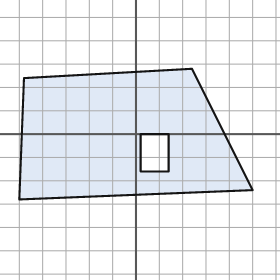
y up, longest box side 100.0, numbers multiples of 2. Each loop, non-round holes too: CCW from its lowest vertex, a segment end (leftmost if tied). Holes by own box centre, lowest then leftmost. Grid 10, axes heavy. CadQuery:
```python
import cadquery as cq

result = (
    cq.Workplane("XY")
    .moveTo(-50.0, -28.0)
    .lineTo(50.0, -24.0)
    .lineTo(24.0, 28.0)
    .lineTo(-48.0, 24.0)
    .close()
    .moveTo(2.0, -16.0)
    .lineTo(14.0, -16.0)
    .lineTo(14.0, 0.0)
    .lineTo(2.0, 0.0)
    .close()
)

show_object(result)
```